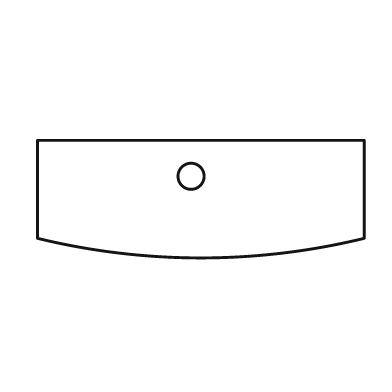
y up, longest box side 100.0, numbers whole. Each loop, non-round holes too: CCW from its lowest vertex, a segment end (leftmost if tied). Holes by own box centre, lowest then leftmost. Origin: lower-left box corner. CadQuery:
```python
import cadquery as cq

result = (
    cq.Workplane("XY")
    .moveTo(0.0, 6.0)
    .threePointArc((50.0, 0.0), (100.0, 6.0))
    .lineTo(100.0, 36.0)
    .lineTo(0.0, 36.0)
    .close()
    .moveTo(47.0, 25.0)
    .circle(4.0)
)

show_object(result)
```